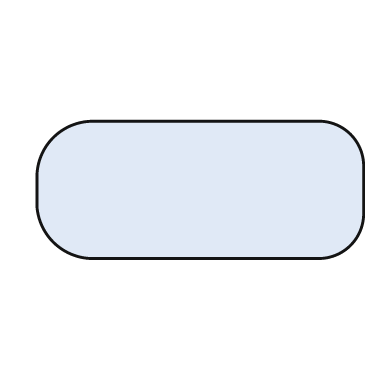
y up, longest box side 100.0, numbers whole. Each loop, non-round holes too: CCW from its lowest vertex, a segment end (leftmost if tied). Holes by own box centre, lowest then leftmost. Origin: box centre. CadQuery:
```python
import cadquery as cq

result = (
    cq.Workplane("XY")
    .moveTo(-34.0, -21.0)
    .lineTo(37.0, -21.0)
    .threePointArc((46.0, -17.0), (50.0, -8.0))
    .lineTo(50.0, 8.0)
    .threePointArc((46.0, 17.0), (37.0, 21.0))
    .lineTo(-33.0, 21.0)
    .threePointArc((-45.0, 16.0), (-50.0, 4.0))
    .lineTo(-50.0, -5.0)
    .threePointArc((-45.0, -16.0), (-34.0, -21.0))
    .close()
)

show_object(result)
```